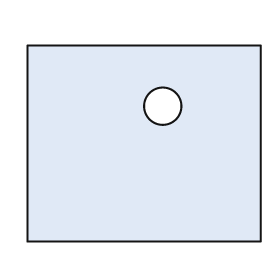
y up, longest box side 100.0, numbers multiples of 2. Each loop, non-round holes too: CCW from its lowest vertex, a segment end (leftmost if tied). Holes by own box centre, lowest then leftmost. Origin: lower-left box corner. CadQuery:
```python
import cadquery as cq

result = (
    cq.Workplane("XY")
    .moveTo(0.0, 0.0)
    .lineTo(100.0, 0.0)
    .lineTo(100.0, 84.0)
    .lineTo(0.0, 84.0)
    .close()
    .moveTo(58.0, 58.0)
    .circle(8.0)
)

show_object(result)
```